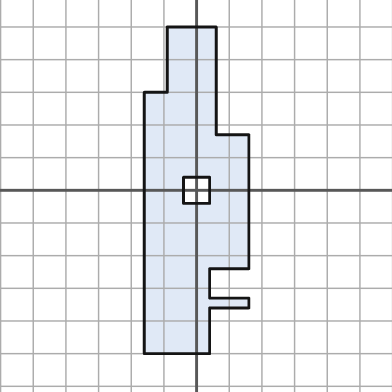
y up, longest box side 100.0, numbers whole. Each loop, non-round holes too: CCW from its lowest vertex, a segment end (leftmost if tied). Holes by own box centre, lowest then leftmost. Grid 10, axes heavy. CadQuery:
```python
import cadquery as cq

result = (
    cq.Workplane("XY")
    .moveTo(-16.0, -50.0)
    .lineTo(4.0, -50.0)
    .lineTo(4.0, -36.0)
    .lineTo(16.0, -36.0)
    .lineTo(16.0, -33.0)
    .lineTo(4.0, -33.0)
    .lineTo(4.0, -24.0)
    .lineTo(16.0, -24.0)
    .lineTo(16.0, 17.0)
    .lineTo(6.0, 17.0)
    .lineTo(6.0, 50.0)
    .lineTo(-9.0, 50.0)
    .lineTo(-9.0, 30.0)
    .lineTo(-16.0, 30.0)
    .close()
    .moveTo(-4.0, -4.0)
    .lineTo(4.0, -4.0)
    .lineTo(4.0, 4.0)
    .lineTo(-4.0, 4.0)
    .close()
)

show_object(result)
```